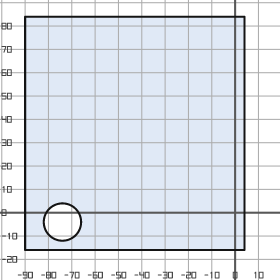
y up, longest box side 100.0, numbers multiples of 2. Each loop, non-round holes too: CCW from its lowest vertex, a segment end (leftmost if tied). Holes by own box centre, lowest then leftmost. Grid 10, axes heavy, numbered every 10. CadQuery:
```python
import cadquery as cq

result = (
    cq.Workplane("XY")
    .moveTo(-90.0, -16.0)
    .lineTo(4.0, -16.0)
    .lineTo(4.0, 84.0)
    .lineTo(-90.0, 84.0)
    .close()
    .moveTo(-74.0, -4.0)
    .circle(8.0)
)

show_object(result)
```